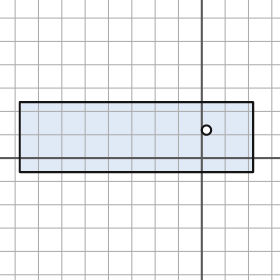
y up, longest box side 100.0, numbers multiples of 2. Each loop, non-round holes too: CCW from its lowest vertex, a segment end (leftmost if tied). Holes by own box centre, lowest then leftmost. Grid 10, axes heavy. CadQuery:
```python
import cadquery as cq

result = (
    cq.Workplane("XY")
    .moveTo(-78.0, -6.0)
    .lineTo(22.0, -6.0)
    .lineTo(22.0, 24.0)
    .lineTo(-78.0, 24.0)
    .close()
    .moveTo(2.0, 12.0)
    .circle(2.0)
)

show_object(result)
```